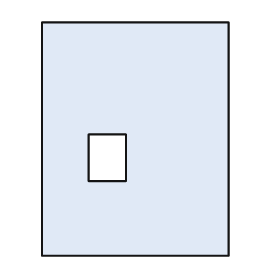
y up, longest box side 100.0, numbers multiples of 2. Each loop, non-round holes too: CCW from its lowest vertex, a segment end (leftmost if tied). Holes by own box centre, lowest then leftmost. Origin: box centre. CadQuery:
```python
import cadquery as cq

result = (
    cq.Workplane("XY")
    .moveTo(-40.0, -50.0)
    .lineTo(40.0, -50.0)
    .lineTo(40.0, 50.0)
    .lineTo(-40.0, 50.0)
    .close()
    .moveTo(-20.0, -18.0)
    .lineTo(-4.0, -18.0)
    .lineTo(-4.0, 2.0)
    .lineTo(-20.0, 2.0)
    .close()
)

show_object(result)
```